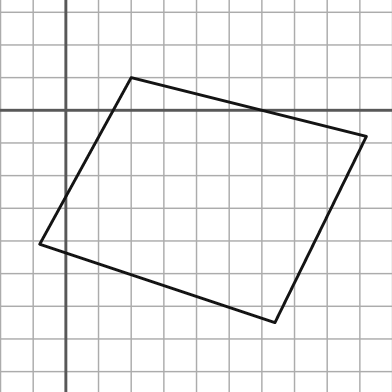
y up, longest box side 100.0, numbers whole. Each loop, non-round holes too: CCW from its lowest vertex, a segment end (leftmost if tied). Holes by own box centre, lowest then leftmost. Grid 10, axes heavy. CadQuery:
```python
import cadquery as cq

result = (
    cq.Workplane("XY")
    .moveTo(64.0, -65.0)
    .lineTo(92.0, -8.0)
    .lineTo(20.0, 10.0)
    .lineTo(-8.0, -41.0)
    .close()
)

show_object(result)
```